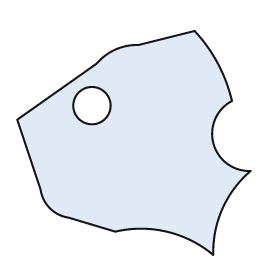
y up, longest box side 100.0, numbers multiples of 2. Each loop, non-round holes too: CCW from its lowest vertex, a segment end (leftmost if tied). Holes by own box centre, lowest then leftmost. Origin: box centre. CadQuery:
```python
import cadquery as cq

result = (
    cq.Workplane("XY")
    .moveTo(34.0, -48.0)
    .threePointArc((38.0, -28.0), (50.0, -12.0))
    .threePointArc((34.0, 0.0), (42.0, 18.0))
    .threePointArc((36.0, 34.0), (26.0, 48.0))
    .lineTo(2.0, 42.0)
    .threePointArc((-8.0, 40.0), (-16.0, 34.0))
    .lineTo(-50.0, 10.0)
    .lineTo(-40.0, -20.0)
    .threePointArc((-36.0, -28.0), (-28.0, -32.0))
    .lineTo(-8.0, -38.0)
    .threePointArc((14.0, -38.0), (34.0, -48.0))
    .close()
    .moveTo(-18.0, 16.0)
    .circle(8.0)
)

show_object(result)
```